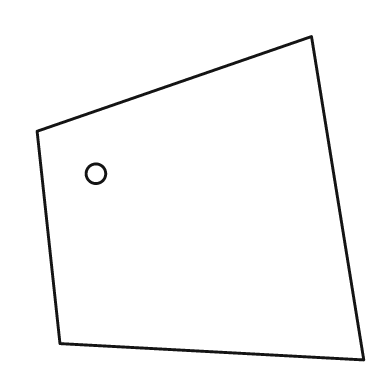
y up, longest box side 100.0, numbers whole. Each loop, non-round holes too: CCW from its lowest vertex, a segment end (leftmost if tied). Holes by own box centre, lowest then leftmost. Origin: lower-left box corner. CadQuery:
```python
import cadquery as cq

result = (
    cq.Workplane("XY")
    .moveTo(100.0, 0.0)
    .lineTo(84.0, 99.0)
    .lineTo(0.0, 70.0)
    .lineTo(7.0, 5.0)
    .close()
    .moveTo(18.0, 57.0)
    .circle(3.0)
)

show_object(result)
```